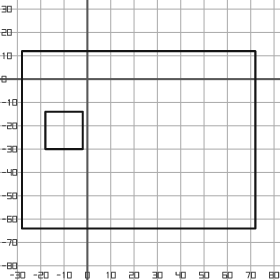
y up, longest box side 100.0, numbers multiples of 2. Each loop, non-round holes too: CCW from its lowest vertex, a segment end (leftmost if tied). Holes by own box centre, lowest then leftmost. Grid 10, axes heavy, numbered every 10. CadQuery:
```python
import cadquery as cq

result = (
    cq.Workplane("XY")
    .moveTo(-28.0, -64.0)
    .lineTo(72.0, -64.0)
    .lineTo(72.0, 12.0)
    .lineTo(-28.0, 12.0)
    .close()
    .moveTo(-18.0, -30.0)
    .lineTo(-2.0, -30.0)
    .lineTo(-2.0, -14.0)
    .lineTo(-18.0, -14.0)
    .close()
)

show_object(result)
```